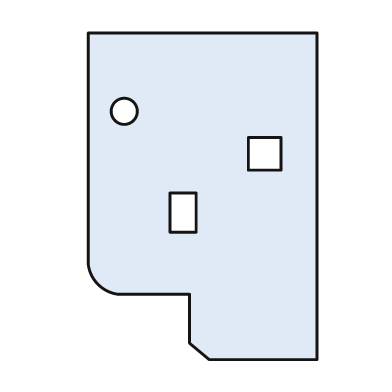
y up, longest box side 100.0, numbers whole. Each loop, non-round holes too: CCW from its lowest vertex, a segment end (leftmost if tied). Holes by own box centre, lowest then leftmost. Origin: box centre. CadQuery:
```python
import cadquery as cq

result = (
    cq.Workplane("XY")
    .moveTo(2.0, -50.0)
    .lineTo(35.0, -50.0)
    .lineTo(35.0, 50.0)
    .lineTo(-35.0, 50.0)
    .lineTo(-35.0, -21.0)
    .threePointArc((-32.0, -27.0), (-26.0, -30.0))
    .lineTo(-4.0, -30.0)
    .lineTo(-4.0, -45.0)
    .close()
    .moveTo(-10.0, -11.0)
    .lineTo(-2.0, -11.0)
    .lineTo(-2.0, 1.0)
    .lineTo(-10.0, 1.0)
    .close()
    .moveTo(14.0, 8.0)
    .lineTo(24.0, 8.0)
    .lineTo(24.0, 18.0)
    .lineTo(14.0, 18.0)
    .close()
    .moveTo(-24.0, 26.0)
    .circle(4.0)
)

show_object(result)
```